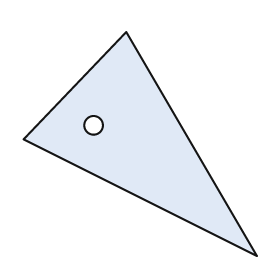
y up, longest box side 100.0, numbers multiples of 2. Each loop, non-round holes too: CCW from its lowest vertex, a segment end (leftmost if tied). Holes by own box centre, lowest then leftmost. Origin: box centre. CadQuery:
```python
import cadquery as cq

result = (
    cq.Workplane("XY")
    .moveTo(50.0, -48.0)
    .lineTo(-6.0, 48.0)
    .lineTo(-50.0, 2.0)
    .close()
    .moveTo(-20.0, 8.0)
    .circle(4.0)
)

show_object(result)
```